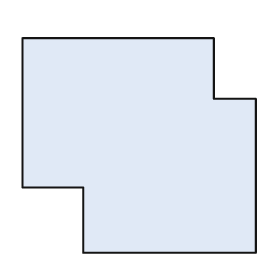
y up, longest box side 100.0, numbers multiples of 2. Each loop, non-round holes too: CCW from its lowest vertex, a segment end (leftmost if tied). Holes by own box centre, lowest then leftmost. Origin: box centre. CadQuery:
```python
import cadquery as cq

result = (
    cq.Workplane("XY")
    .moveTo(-24.0, -46.0)
    .lineTo(50.0, -46.0)
    .lineTo(50.0, 20.0)
    .lineTo(32.0, 20.0)
    .lineTo(32.0, 46.0)
    .lineTo(-50.0, 46.0)
    .lineTo(-50.0, -18.0)
    .lineTo(-24.0, -18.0)
    .close()
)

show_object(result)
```